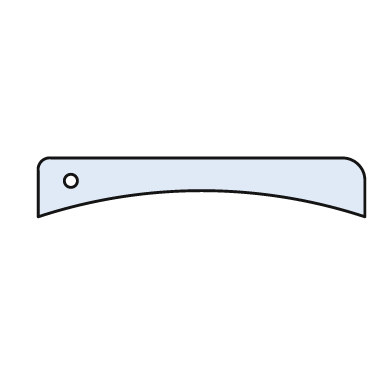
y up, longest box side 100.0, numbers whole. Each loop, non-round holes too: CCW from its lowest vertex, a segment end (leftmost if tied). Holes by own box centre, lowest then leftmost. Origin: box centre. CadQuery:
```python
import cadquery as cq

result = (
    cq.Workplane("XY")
    .moveTo(-50.0, -9.0)
    .threePointArc((0.0, -1.0), (50.0, -9.0))
    .lineTo(50.0, 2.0)
    .threePointArc((48.0, 7.0), (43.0, 9.0))
    .lineTo(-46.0, 9.0)
    .threePointArc((-49.0, 8.0), (-50.0, 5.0))
    .close()
    .moveTo(-40.0, 2.0)
    .circle(2.0)
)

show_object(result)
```